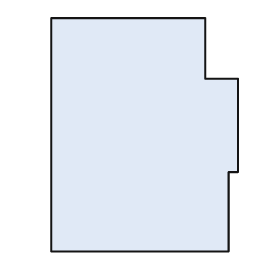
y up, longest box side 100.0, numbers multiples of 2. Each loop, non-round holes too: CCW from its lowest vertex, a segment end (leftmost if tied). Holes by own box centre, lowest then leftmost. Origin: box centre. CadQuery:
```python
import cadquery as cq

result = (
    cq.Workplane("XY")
    .moveTo(-40.0, -50.0)
    .lineTo(36.0, -50.0)
    .lineTo(36.0, -16.0)
    .lineTo(40.0, -16.0)
    .lineTo(40.0, 24.0)
    .lineTo(26.0, 24.0)
    .lineTo(26.0, 50.0)
    .lineTo(-40.0, 50.0)
    .close()
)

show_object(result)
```